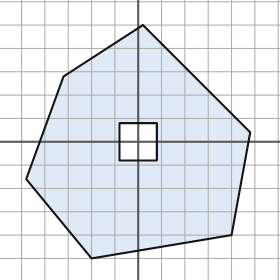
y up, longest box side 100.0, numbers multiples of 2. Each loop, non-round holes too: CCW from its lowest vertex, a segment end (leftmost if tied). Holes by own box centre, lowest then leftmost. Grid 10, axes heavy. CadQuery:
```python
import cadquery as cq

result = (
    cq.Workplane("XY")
    .moveTo(-20.0, -50.0)
    .lineTo(40.0, -40.0)
    .lineTo(48.0, 4.0)
    .lineTo(2.0, 50.0)
    .lineTo(-32.0, 28.0)
    .lineTo(-48.0, -16.0)
    .close()
    .moveTo(-8.0, -8.0)
    .lineTo(8.0, -8.0)
    .lineTo(8.0, 8.0)
    .lineTo(-8.0, 8.0)
    .close()
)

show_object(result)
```